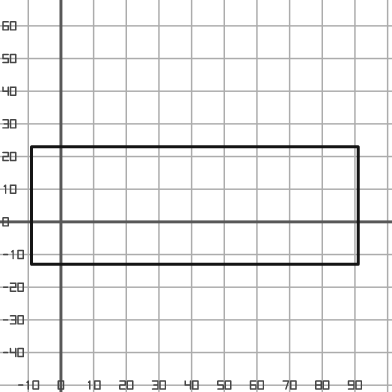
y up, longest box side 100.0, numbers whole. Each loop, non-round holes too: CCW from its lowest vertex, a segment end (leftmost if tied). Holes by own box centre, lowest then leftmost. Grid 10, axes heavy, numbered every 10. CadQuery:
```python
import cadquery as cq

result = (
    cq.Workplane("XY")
    .moveTo(-9.0, -13.0)
    .lineTo(91.0, -13.0)
    .lineTo(91.0, 23.0)
    .lineTo(-9.0, 23.0)
    .close()
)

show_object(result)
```